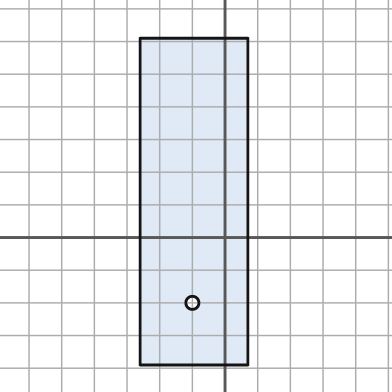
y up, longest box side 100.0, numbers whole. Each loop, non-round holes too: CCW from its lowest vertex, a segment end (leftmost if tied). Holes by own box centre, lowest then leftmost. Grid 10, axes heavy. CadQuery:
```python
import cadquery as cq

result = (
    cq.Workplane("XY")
    .moveTo(-26.0, -39.0)
    .lineTo(7.0, -39.0)
    .lineTo(7.0, 61.0)
    .lineTo(-26.0, 61.0)
    .close()
    .moveTo(-10.0, -20.0)
    .circle(2.0)
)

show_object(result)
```